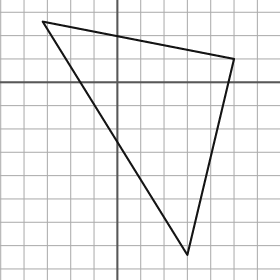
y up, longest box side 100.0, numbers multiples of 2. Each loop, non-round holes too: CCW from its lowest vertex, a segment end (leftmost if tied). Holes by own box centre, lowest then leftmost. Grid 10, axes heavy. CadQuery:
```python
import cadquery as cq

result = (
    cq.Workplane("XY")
    .moveTo(30.0, -74.0)
    .lineTo(50.0, 10.0)
    .lineTo(-32.0, 26.0)
    .close()
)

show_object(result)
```